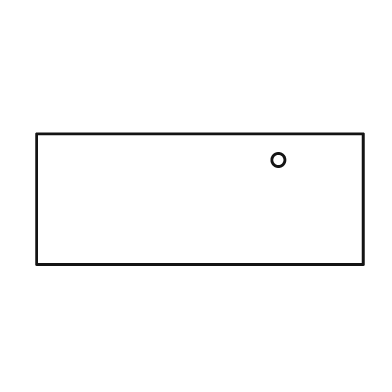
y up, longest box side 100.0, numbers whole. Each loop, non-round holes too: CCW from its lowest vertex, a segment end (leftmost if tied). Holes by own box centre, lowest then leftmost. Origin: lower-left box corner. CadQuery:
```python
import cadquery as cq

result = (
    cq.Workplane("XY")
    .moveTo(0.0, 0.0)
    .lineTo(100.0, 0.0)
    .lineTo(100.0, 40.0)
    .lineTo(0.0, 40.0)
    .close()
    .moveTo(74.0, 32.0)
    .circle(2.0)
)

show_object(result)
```